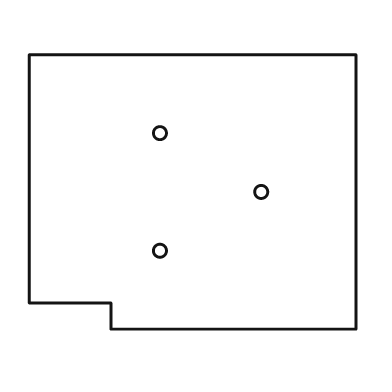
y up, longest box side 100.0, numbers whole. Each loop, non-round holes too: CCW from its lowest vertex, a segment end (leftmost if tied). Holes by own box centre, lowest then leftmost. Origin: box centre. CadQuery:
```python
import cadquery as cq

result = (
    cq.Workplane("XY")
    .moveTo(-25.0, -42.0)
    .lineTo(50.0, -42.0)
    .lineTo(50.0, 42.0)
    .lineTo(-50.0, 42.0)
    .lineTo(-50.0, -34.0)
    .lineTo(-25.0, -34.0)
    .close()
    .moveTo(-10.0, -18.0)
    .circle(2.0)
    .moveTo(21.0, 0.0)
    .circle(2.0)
    .moveTo(-10.0, 18.0)
    .circle(2.0)
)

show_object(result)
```